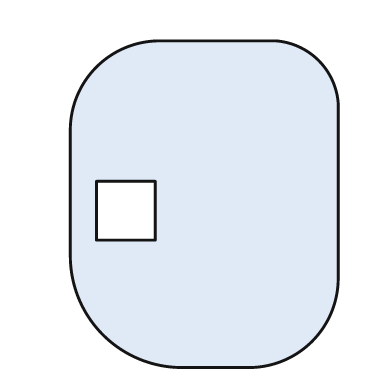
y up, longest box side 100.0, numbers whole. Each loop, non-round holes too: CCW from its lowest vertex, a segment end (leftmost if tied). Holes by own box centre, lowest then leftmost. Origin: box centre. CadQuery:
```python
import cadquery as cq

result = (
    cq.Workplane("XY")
    .moveTo(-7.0, -50.0)
    .lineTo(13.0, -50.0)
    .threePointArc((33.0, -42.0), (41.0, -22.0))
    .lineTo(41.0, 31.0)
    .threePointArc((35.0, 44.0), (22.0, 50.0))
    .lineTo(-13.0, 50.0)
    .threePointArc((-33.0, 42.0), (-41.0, 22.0))
    .lineTo(-41.0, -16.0)
    .threePointArc((-31.0, -40.0), (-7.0, -50.0))
    .close()
    .moveTo(-33.0, -11.0)
    .lineTo(-15.0, -11.0)
    .lineTo(-15.0, 7.0)
    .lineTo(-33.0, 7.0)
    .close()
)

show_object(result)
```